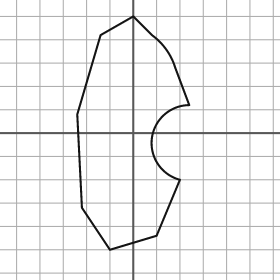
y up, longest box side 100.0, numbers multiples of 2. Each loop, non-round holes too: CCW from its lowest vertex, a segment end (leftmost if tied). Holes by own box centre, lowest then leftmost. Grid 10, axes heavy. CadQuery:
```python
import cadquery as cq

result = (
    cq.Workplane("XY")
    .moveTo(-10.0, -50.0)
    .lineTo(10.0, -44.0)
    .lineTo(20.0, -20.0)
    .threePointArc((8.0, -2.0), (24.0, 12.0))
    .lineTo(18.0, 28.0)
    .threePointArc((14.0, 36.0), (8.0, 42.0))
    .lineTo(0.0, 50.0)
    .lineTo(-14.0, 42.0)
    .lineTo(-24.0, 8.0)
    .lineTo(-22.0, -32.0)
    .close()
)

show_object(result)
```